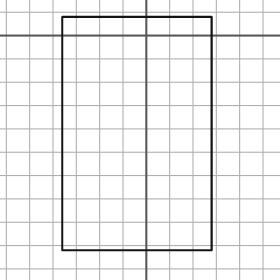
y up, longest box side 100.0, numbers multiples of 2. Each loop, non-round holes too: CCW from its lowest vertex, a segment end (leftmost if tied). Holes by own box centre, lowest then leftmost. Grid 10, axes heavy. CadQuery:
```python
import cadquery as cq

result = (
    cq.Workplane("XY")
    .moveTo(-36.0, -92.0)
    .lineTo(28.0, -92.0)
    .lineTo(28.0, 8.0)
    .lineTo(-36.0, 8.0)
    .close()
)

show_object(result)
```